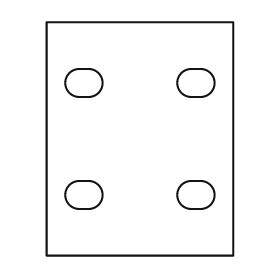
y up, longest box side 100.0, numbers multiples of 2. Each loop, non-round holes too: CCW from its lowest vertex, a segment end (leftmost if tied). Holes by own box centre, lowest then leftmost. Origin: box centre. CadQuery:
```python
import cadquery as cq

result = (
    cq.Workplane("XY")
    .moveTo(-40.0, -50.0)
    .lineTo(40.0, -50.0)
    .lineTo(40.0, 50.0)
    .lineTo(-40.0, 50.0)
    .close()
    .moveTo(-26.0, -30.0)
    .lineTo(-22.0, -30.0)
    .threePointArc((-16.0, -24.0), (-22.0, -18.0))
    .lineTo(-26.0, -18.0)
    .threePointArc((-32.0, -24.0), (-26.0, -30.0))
    .close()
    .moveTo(22.0, -30.0)
    .lineTo(26.0, -30.0)
    .threePointArc((32.0, -24.0), (26.0, -18.0))
    .lineTo(22.0, -18.0)
    .threePointArc((16.0, -24.0), (22.0, -30.0))
    .close()
    .moveTo(-26.0, 18.0)
    .lineTo(-22.0, 18.0)
    .threePointArc((-16.0, 24.0), (-22.0, 30.0))
    .lineTo(-26.0, 30.0)
    .threePointArc((-32.0, 24.0), (-26.0, 18.0))
    .close()
    .moveTo(22.0, 18.0)
    .lineTo(26.0, 18.0)
    .threePointArc((32.0, 24.0), (26.0, 30.0))
    .lineTo(22.0, 30.0)
    .threePointArc((16.0, 24.0), (22.0, 18.0))
    .close()
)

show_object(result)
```